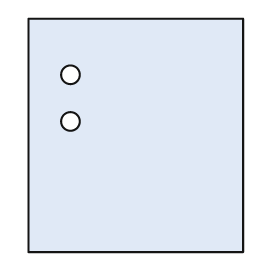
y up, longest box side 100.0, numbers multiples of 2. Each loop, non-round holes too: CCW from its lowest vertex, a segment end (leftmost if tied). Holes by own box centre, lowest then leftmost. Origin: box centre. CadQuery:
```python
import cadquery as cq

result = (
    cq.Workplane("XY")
    .moveTo(-46.0, -50.0)
    .lineTo(46.0, -50.0)
    .lineTo(46.0, 50.0)
    .lineTo(-46.0, 50.0)
    .close()
    .moveTo(-28.0, 6.0)
    .circle(4.0)
    .moveTo(-28.0, 26.0)
    .circle(4.0)
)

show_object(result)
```